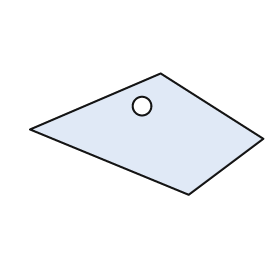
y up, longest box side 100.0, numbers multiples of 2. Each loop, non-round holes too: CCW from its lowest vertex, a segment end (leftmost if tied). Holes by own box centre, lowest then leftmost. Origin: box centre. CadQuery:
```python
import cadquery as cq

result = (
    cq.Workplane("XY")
    .moveTo(18.0, -26.0)
    .lineTo(50.0, -2.0)
    .lineTo(6.0, 26.0)
    .lineTo(-50.0, 2.0)
    .close()
    .moveTo(-2.0, 12.0)
    .circle(4.0)
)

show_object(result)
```